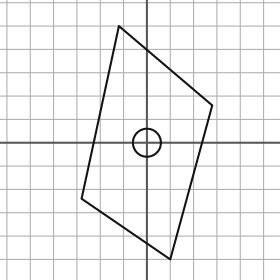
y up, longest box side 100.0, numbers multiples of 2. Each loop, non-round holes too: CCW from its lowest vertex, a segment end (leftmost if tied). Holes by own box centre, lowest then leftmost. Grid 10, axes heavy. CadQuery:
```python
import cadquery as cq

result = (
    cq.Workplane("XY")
    .moveTo(10.0, -50.0)
    .lineTo(28.0, 16.0)
    .lineTo(-12.0, 50.0)
    .lineTo(-28.0, -24.0)
    .close()
    .moveTo(0.0, 0.0)
    .circle(6.0)
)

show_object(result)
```